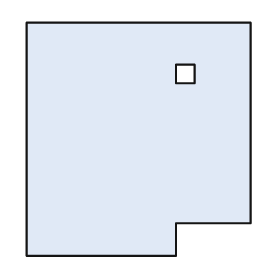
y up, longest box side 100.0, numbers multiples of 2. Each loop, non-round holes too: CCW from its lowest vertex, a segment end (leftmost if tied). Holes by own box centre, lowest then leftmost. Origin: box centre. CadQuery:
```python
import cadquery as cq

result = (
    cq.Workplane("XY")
    .moveTo(-48.0, -50.0)
    .lineTo(16.0, -50.0)
    .lineTo(16.0, -36.0)
    .lineTo(48.0, -36.0)
    .lineTo(48.0, 50.0)
    .lineTo(-48.0, 50.0)
    .close()
    .moveTo(16.0, 24.0)
    .lineTo(24.0, 24.0)
    .lineTo(24.0, 32.0)
    .lineTo(16.0, 32.0)
    .close()
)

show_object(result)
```